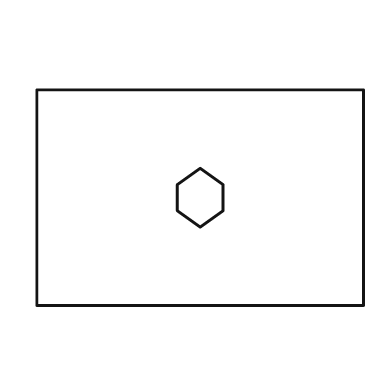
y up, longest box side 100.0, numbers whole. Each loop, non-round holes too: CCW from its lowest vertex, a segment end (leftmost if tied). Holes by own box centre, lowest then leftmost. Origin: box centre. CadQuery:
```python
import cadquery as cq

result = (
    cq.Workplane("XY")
    .moveTo(-50.0, -33.0)
    .lineTo(50.0, -33.0)
    .lineTo(50.0, 33.0)
    .lineTo(-50.0, 33.0)
    .close()
    .moveTo(0.0, -9.0)
    .lineTo(7.0, -4.0)
    .lineTo(7.0, 4.0)
    .lineTo(0.0, 9.0)
    .lineTo(-7.0, 4.0)
    .lineTo(-7.0, -4.0)
    .close()
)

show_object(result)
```